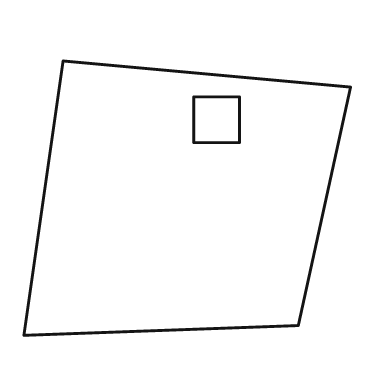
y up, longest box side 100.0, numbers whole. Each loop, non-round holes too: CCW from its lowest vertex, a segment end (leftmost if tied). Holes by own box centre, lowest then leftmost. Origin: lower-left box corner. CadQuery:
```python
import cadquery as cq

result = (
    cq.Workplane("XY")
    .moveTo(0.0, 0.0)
    .lineTo(84.0, 3.0)
    .lineTo(100.0, 76.0)
    .lineTo(12.0, 84.0)
    .close()
    .moveTo(52.0, 59.0)
    .lineTo(66.0, 59.0)
    .lineTo(66.0, 73.0)
    .lineTo(52.0, 73.0)
    .close()
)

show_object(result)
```